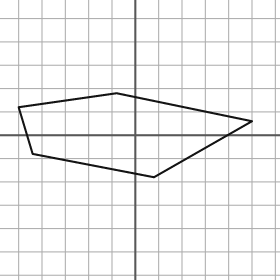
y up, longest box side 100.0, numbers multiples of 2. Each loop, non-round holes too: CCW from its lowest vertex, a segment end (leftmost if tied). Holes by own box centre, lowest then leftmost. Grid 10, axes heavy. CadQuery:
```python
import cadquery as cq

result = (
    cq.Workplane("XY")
    .moveTo(8.0, -18.0)
    .lineTo(50.0, 6.0)
    .lineTo(-8.0, 18.0)
    .lineTo(-50.0, 12.0)
    .lineTo(-44.0, -8.0)
    .close()
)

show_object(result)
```